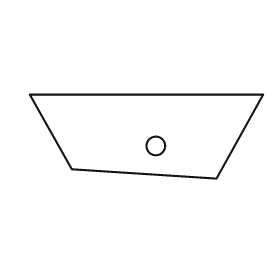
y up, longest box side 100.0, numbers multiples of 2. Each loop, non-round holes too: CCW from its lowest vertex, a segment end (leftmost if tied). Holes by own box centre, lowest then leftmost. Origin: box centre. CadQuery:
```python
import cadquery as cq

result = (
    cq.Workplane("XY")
    .moveTo(30.0, -18.0)
    .lineTo(50.0, 18.0)
    .lineTo(-50.0, 18.0)
    .lineTo(-32.0, -14.0)
    .close()
    .moveTo(4.0, -4.0)
    .circle(4.0)
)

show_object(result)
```